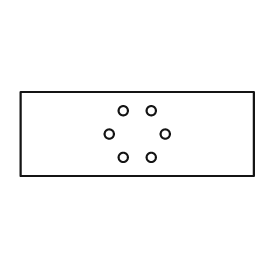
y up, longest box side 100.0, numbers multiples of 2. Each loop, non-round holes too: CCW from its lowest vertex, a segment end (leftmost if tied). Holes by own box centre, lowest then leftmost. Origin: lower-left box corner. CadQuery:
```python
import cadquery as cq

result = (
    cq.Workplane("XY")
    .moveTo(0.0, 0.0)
    .lineTo(100.0, 0.0)
    .lineTo(100.0, 36.0)
    .lineTo(0.0, 36.0)
    .close()
    .moveTo(44.0, 8.0)
    .circle(2.0)
    .moveTo(56.0, 8.0)
    .circle(2.0)
    .moveTo(38.0, 18.0)
    .circle(2.0)
    .moveTo(62.0, 18.0)
    .circle(2.0)
    .moveTo(44.0, 28.0)
    .circle(2.0)
    .moveTo(56.0, 28.0)
    .circle(2.0)
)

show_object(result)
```